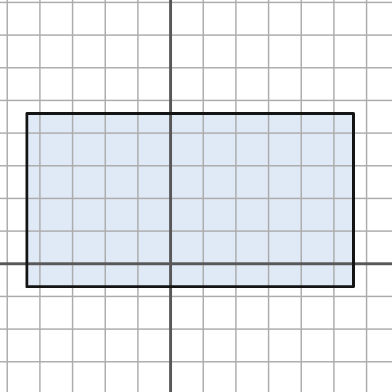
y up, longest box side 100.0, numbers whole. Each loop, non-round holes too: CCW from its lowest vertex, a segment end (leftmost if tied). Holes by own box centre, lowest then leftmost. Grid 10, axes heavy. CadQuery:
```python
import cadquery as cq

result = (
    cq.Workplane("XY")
    .moveTo(-44.0, -7.0)
    .lineTo(56.0, -7.0)
    .lineTo(56.0, 46.0)
    .lineTo(-44.0, 46.0)
    .close()
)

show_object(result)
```